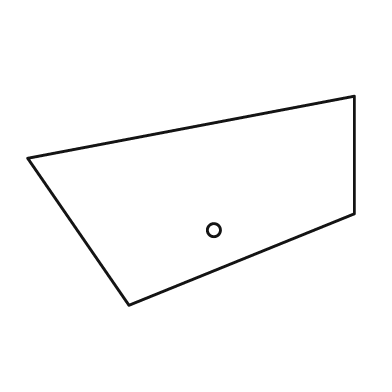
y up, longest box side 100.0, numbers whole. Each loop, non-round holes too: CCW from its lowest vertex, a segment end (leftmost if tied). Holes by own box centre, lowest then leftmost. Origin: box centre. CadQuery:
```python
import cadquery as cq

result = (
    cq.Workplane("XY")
    .moveTo(-19.0, -32.0)
    .lineTo(50.0, -4.0)
    .lineTo(50.0, 32.0)
    .lineTo(-50.0, 13.0)
    .close()
    .moveTo(7.0, -9.0)
    .circle(2.0)
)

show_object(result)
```